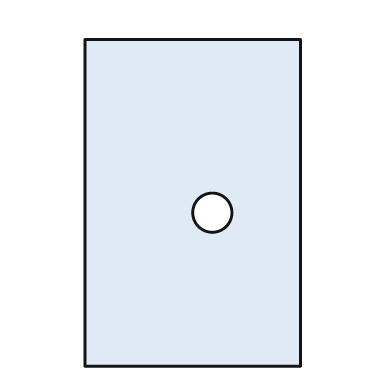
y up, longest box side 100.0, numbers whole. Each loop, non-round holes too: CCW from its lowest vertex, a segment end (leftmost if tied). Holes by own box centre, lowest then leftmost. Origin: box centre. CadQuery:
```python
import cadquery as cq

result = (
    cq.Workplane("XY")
    .moveTo(-33.0, -50.0)
    .lineTo(33.0, -50.0)
    .lineTo(33.0, 50.0)
    .lineTo(-33.0, 50.0)
    .close()
    .moveTo(6.0, -3.0)
    .circle(6.0)
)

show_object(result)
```